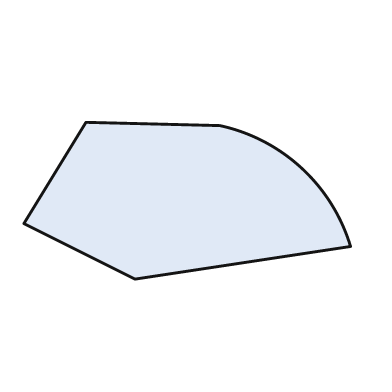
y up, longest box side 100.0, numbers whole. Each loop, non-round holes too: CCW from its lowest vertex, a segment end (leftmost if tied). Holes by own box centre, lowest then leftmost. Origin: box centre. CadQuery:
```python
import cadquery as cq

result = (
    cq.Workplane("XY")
    .moveTo(-16.0, -24.0)
    .lineTo(50.0, -14.0)
    .threePointArc((35.0, 10.0), (10.0, 23.0))
    .lineTo(-31.0, 24.0)
    .lineTo(-50.0, -7.0)
    .close()
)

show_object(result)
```